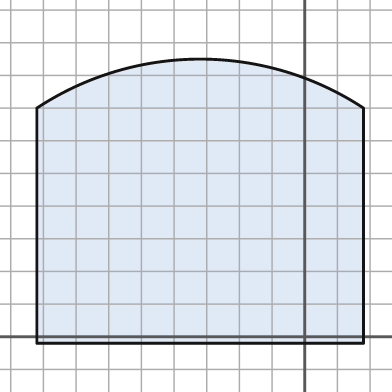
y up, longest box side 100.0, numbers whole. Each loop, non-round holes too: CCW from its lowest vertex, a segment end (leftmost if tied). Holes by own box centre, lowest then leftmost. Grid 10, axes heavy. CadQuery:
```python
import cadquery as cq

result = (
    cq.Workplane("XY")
    .moveTo(-82.0, -2.0)
    .lineTo(18.0, -2.0)
    .lineTo(18.0, 70.0)
    .threePointArc((-32.0, 85.0), (-82.0, 70.0))
    .close()
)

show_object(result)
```